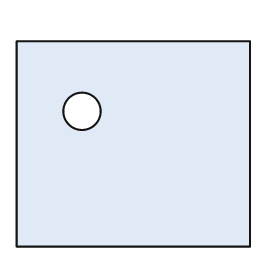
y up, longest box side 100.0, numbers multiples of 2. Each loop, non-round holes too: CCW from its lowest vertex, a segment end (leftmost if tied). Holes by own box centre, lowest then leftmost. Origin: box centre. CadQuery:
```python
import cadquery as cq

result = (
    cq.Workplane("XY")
    .moveTo(-50.0, -44.0)
    .lineTo(50.0, -44.0)
    .lineTo(50.0, 44.0)
    .lineTo(-50.0, 44.0)
    .close()
    .moveTo(-22.0, 14.0)
    .circle(8.0)
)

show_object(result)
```